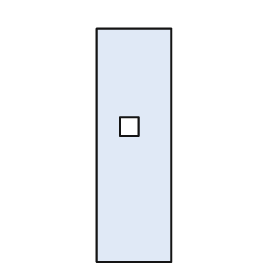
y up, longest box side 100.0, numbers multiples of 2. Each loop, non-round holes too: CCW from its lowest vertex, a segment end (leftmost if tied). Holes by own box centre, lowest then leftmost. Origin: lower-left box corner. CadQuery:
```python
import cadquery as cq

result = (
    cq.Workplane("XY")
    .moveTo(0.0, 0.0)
    .lineTo(32.0, 0.0)
    .lineTo(32.0, 100.0)
    .lineTo(0.0, 100.0)
    .close()
    .moveTo(10.0, 54.0)
    .lineTo(18.0, 54.0)
    .lineTo(18.0, 62.0)
    .lineTo(10.0, 62.0)
    .close()
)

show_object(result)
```